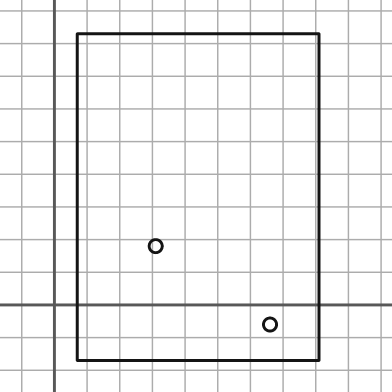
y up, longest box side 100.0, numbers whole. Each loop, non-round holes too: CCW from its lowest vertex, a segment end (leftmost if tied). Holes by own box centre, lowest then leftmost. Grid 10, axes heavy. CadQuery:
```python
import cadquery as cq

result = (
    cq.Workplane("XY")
    .moveTo(7.0, -17.0)
    .lineTo(81.0, -17.0)
    .lineTo(81.0, 83.0)
    .lineTo(7.0, 83.0)
    .close()
    .moveTo(66.0, -6.0)
    .circle(2.0)
    .moveTo(31.0, 18.0)
    .circle(2.0)
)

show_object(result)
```